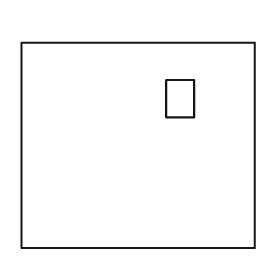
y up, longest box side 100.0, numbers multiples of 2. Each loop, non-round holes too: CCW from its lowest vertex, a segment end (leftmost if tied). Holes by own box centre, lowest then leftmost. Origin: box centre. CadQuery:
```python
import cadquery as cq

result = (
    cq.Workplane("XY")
    .moveTo(-50.0, -44.0)
    .lineTo(50.0, -44.0)
    .lineTo(50.0, 44.0)
    .lineTo(-50.0, 44.0)
    .close()
    .moveTo(12.0, 12.0)
    .lineTo(24.0, 12.0)
    .lineTo(24.0, 28.0)
    .lineTo(12.0, 28.0)
    .close()
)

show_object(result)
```